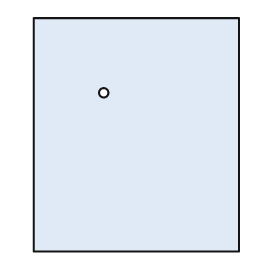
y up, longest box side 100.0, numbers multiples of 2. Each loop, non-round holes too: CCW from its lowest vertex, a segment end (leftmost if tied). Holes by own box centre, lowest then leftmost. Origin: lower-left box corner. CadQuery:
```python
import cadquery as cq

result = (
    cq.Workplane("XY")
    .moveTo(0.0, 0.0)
    .lineTo(88.0, 0.0)
    .lineTo(88.0, 100.0)
    .lineTo(0.0, 100.0)
    .close()
    .moveTo(30.0, 68.0)
    .circle(2.0)
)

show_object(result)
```